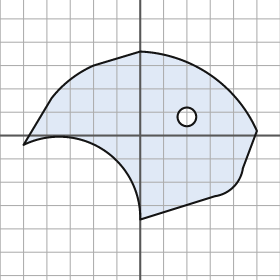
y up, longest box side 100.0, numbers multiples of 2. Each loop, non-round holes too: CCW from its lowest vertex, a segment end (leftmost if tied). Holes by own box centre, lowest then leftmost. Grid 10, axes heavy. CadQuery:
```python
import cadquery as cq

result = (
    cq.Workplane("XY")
    .moveTo(0.0, -36.0)
    .lineTo(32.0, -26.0)
    .threePointArc((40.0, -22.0), (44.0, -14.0))
    .lineTo(50.0, 2.0)
    .threePointArc((30.0, 26.0), (0.0, 36.0))
    .lineTo(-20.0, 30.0)
    .threePointArc((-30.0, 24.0), (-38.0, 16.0))
    .lineTo(-50.0, -4.0)
    .threePointArc((-16.0, -6.0), (0.0, -36.0))
    .close()
    .moveTo(20.0, 8.0)
    .circle(4.0)
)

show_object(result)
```